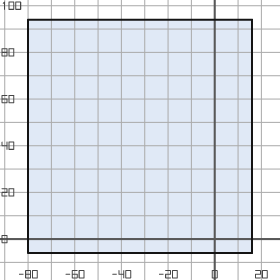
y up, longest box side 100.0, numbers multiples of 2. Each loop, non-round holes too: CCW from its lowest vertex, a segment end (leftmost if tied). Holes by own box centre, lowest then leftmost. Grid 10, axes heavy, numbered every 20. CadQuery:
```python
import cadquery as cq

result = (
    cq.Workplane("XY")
    .moveTo(-80.0, -6.0)
    .lineTo(16.0, -6.0)
    .lineTo(16.0, 94.0)
    .lineTo(-80.0, 94.0)
    .close()
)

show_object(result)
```